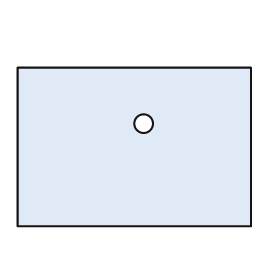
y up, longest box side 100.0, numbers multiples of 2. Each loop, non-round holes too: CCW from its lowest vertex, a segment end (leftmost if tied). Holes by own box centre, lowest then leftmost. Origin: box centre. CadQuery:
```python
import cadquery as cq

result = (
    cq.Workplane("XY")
    .moveTo(-50.0, -34.0)
    .lineTo(50.0, -34.0)
    .lineTo(50.0, 34.0)
    .lineTo(-50.0, 34.0)
    .close()
    .moveTo(4.0, 10.0)
    .circle(4.0)
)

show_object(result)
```